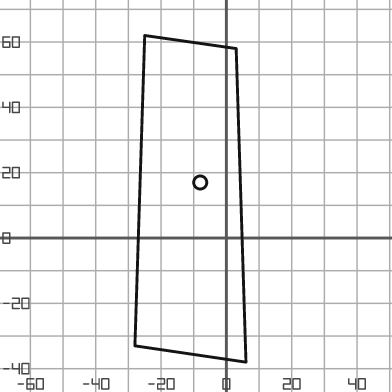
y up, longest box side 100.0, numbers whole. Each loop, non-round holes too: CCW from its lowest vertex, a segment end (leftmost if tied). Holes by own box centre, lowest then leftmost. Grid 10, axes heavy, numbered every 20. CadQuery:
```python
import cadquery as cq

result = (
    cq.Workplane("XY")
    .moveTo(6.0, -38.0)
    .lineTo(3.0, 58.0)
    .lineTo(-25.0, 62.0)
    .lineTo(-28.0, -33.0)
    .close()
    .moveTo(-8.0, 17.0)
    .circle(2.0)
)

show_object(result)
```